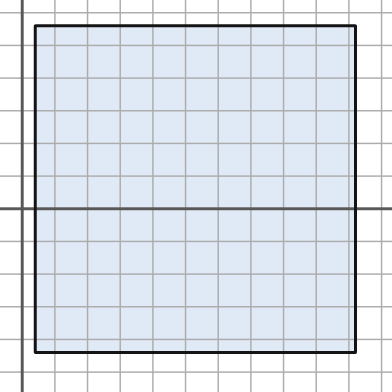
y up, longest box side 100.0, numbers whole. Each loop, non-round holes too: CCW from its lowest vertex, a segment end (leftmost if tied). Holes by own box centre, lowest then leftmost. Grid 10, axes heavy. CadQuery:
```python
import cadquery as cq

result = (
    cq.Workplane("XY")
    .moveTo(4.0, -44.0)
    .lineTo(102.0, -44.0)
    .lineTo(102.0, 56.0)
    .lineTo(4.0, 56.0)
    .close()
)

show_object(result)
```